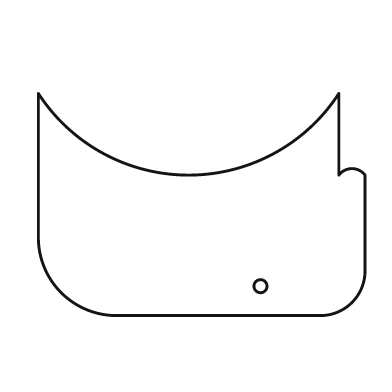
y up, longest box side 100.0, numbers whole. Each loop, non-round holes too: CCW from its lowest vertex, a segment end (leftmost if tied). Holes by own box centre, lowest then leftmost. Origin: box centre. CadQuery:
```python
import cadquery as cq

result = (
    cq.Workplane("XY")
    .moveTo(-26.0, -34.0)
    .lineTo(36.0, -34.0)
    .threePointArc((46.0, -30.0), (50.0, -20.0))
    .lineTo(50.0, 9.0)
    .threePointArc((46.0, 11.0), (42.0, 9.0))
    .lineTo(42.0, 34.0)
    .threePointArc((-4.0, 9.0), (-50.0, 34.0))
    .lineTo(-50.0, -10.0)
    .threePointArc((-43.0, -27.0), (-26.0, -34.0))
    .close()
    .moveTo(18.0, -25.0)
    .circle(2.0)
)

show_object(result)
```